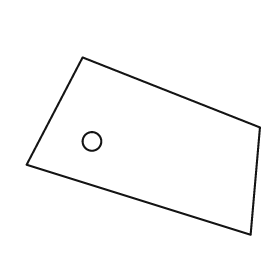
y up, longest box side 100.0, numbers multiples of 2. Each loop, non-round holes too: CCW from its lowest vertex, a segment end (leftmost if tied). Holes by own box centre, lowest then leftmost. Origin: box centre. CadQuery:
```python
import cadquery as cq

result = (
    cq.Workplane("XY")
    .moveTo(46.0, -38.0)
    .lineTo(50.0, 8.0)
    .lineTo(-26.0, 38.0)
    .lineTo(-50.0, -8.0)
    .close()
    .moveTo(-22.0, 2.0)
    .circle(4.0)
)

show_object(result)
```